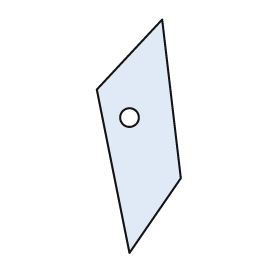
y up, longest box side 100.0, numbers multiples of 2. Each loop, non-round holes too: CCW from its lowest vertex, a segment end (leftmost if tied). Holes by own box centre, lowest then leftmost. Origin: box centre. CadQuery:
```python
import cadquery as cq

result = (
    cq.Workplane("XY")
    .moveTo(-4.0, -50.0)
    .lineTo(18.0, -18.0)
    .lineTo(10.0, 50.0)
    .lineTo(-18.0, 20.0)
    .close()
    .moveTo(-4.0, 8.0)
    .circle(4.0)
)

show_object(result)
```